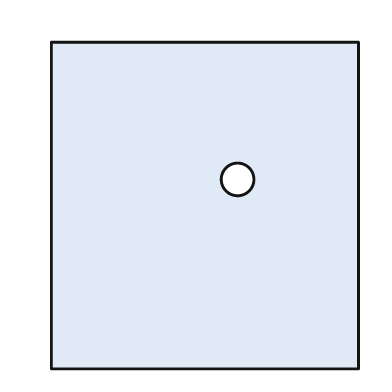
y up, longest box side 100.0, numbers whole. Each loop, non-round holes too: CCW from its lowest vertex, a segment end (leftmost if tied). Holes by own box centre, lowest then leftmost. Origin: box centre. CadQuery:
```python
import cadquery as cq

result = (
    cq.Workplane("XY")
    .moveTo(-47.0, -50.0)
    .lineTo(47.0, -50.0)
    .lineTo(47.0, 50.0)
    .lineTo(-47.0, 50.0)
    .close()
    .moveTo(10.0, 8.0)
    .circle(5.0)
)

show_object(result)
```